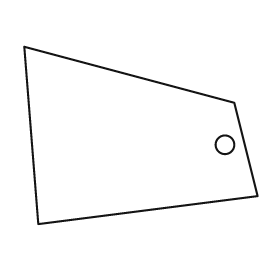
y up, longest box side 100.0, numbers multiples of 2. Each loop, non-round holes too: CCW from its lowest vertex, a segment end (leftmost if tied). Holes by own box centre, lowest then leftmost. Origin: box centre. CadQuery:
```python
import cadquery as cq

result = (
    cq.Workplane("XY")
    .moveTo(-44.0, -38.0)
    .lineTo(50.0, -26.0)
    .lineTo(40.0, 14.0)
    .lineTo(-50.0, 38.0)
    .close()
    .moveTo(36.0, -4.0)
    .circle(4.0)
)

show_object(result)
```